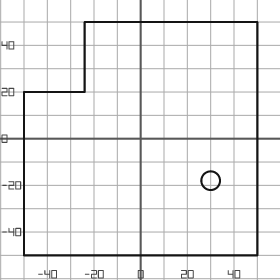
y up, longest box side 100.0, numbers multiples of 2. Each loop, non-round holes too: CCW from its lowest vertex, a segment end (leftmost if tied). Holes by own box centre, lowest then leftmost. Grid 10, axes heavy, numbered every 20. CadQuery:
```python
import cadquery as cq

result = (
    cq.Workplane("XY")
    .moveTo(-50.0, -50.0)
    .lineTo(50.0, -50.0)
    .lineTo(50.0, 50.0)
    .lineTo(-24.0, 50.0)
    .lineTo(-24.0, 20.0)
    .lineTo(-50.0, 20.0)
    .close()
    .moveTo(30.0, -18.0)
    .circle(4.0)
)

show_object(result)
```